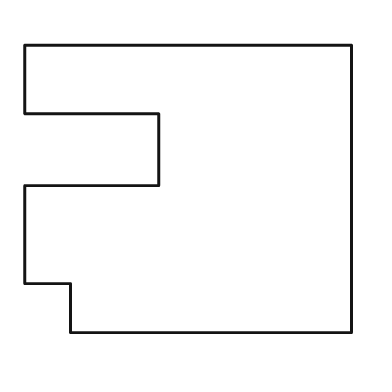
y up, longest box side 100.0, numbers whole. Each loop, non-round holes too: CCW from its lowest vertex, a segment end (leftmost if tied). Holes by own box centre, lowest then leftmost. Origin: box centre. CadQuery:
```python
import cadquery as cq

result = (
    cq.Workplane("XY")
    .moveTo(-36.0, -44.0)
    .lineTo(50.0, -44.0)
    .lineTo(50.0, 44.0)
    .lineTo(-50.0, 44.0)
    .lineTo(-50.0, 23.0)
    .lineTo(-9.0, 23.0)
    .lineTo(-9.0, 1.0)
    .lineTo(-50.0, 1.0)
    .lineTo(-50.0, -29.0)
    .lineTo(-36.0, -29.0)
    .close()
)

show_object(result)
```